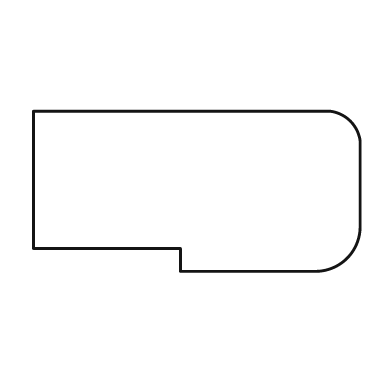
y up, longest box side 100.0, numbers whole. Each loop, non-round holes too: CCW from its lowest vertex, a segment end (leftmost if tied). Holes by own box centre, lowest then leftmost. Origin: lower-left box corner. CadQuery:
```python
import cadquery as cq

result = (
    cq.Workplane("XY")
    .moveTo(45.0, 0.0)
    .lineTo(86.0, 0.0)
    .threePointArc((96.0, 4.0), (100.0, 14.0))
    .lineTo(100.0, 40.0)
    .threePointArc((97.0, 46.0), (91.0, 49.0))
    .lineTo(0.0, 49.0)
    .lineTo(0.0, 7.0)
    .lineTo(45.0, 7.0)
    .close()
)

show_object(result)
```